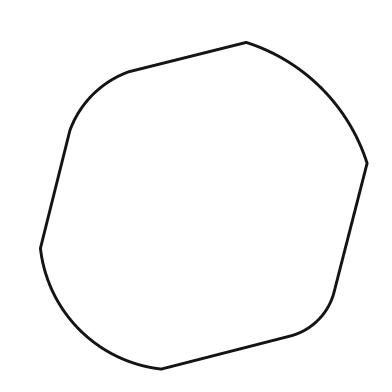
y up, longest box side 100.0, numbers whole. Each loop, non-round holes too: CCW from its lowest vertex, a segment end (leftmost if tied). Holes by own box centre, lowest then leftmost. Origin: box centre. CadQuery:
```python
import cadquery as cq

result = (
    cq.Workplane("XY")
    .moveTo(-13.0, -50.0)
    .lineTo(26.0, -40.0)
    .threePointArc((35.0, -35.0), (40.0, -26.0))
    .lineTo(50.0, 13.0)
    .threePointArc((36.0, 36.0), (13.0, 50.0))
    .lineTo(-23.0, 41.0)
    .threePointArc((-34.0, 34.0), (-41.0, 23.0))
    .lineTo(-50.0, -13.0)
    .threePointArc((-38.0, -38.0), (-13.0, -50.0))
    .close()
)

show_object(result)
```